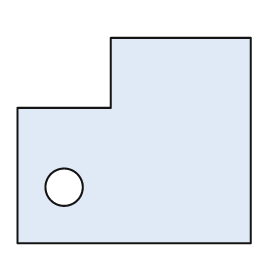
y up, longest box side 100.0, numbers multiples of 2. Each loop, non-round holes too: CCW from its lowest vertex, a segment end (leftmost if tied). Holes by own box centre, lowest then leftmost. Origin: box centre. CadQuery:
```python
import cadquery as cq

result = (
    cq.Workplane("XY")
    .moveTo(-50.0, -44.0)
    .lineTo(50.0, -44.0)
    .lineTo(50.0, 44.0)
    .lineTo(-10.0, 44.0)
    .lineTo(-10.0, 14.0)
    .lineTo(-50.0, 14.0)
    .close()
    .moveTo(-30.0, -20.0)
    .circle(8.0)
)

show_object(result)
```